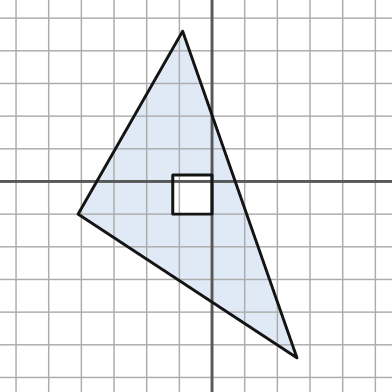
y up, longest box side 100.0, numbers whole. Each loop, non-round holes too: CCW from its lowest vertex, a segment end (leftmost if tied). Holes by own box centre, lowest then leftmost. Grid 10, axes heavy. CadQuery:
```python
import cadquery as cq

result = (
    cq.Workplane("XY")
    .moveTo(26.0, -54.0)
    .lineTo(-9.0, 46.0)
    .lineTo(-41.0, -10.0)
    .close()
    .moveTo(-12.0, -10.0)
    .lineTo(0.0, -10.0)
    .lineTo(0.0, 2.0)
    .lineTo(-12.0, 2.0)
    .close()
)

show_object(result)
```